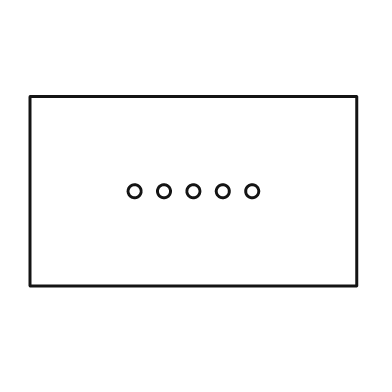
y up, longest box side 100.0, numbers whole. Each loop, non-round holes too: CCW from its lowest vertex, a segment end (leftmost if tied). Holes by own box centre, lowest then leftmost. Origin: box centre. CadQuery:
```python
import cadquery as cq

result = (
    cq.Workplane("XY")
    .moveTo(-50.0, -29.0)
    .lineTo(50.0, -29.0)
    .lineTo(50.0, 29.0)
    .lineTo(-50.0, 29.0)
    .close()
    .moveTo(-18.0, 0.0)
    .circle(2.0)
    .moveTo(-9.0, 0.0)
    .circle(2.0)
    .moveTo(0.0, 0.0)
    .circle(2.0)
    .moveTo(9.0, 0.0)
    .circle(2.0)
    .moveTo(18.0, 0.0)
    .circle(2.0)
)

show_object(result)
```